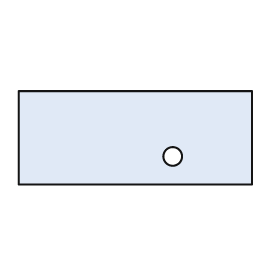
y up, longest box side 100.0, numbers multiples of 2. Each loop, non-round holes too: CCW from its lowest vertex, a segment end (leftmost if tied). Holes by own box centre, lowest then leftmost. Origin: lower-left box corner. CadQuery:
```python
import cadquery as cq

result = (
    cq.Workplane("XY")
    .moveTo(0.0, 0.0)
    .lineTo(100.0, 0.0)
    .lineTo(100.0, 40.0)
    .lineTo(0.0, 40.0)
    .close()
    .moveTo(66.0, 12.0)
    .circle(4.0)
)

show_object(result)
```